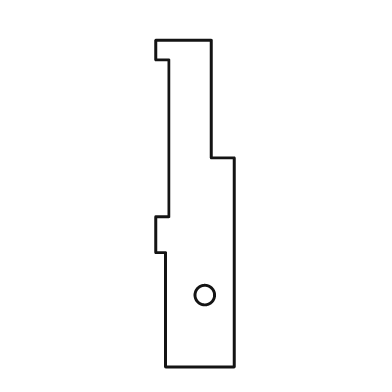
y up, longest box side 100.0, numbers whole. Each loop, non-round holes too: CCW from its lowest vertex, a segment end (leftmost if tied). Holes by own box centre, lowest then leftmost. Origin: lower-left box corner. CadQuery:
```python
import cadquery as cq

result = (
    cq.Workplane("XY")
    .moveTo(3.0, 0.0)
    .lineTo(24.0, 0.0)
    .lineTo(24.0, 64.0)
    .lineTo(17.0, 64.0)
    .lineTo(17.0, 100.0)
    .lineTo(0.0, 100.0)
    .lineTo(0.0, 94.0)
    .lineTo(4.0, 94.0)
    .lineTo(4.0, 46.0)
    .lineTo(0.0, 46.0)
    .lineTo(0.0, 35.0)
    .lineTo(3.0, 35.0)
    .close()
    .moveTo(15.0, 22.0)
    .circle(3.0)
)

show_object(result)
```